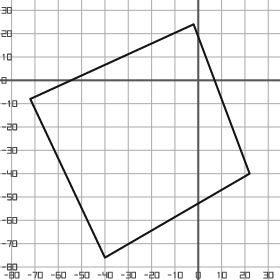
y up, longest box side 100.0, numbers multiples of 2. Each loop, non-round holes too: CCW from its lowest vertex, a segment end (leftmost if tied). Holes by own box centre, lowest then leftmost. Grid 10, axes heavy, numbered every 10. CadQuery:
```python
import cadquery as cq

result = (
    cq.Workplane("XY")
    .moveTo(-40.0, -76.0)
    .lineTo(22.0, -40.0)
    .lineTo(-2.0, 24.0)
    .lineTo(-72.0, -8.0)
    .close()
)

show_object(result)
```